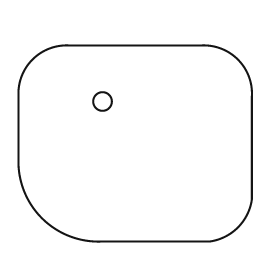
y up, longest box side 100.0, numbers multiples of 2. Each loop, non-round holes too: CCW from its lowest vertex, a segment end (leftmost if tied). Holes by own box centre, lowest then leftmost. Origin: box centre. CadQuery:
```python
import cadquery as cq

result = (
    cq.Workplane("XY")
    .moveTo(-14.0, -42.0)
    .lineTo(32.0, -42.0)
    .threePointArc((44.0, -36.0), (50.0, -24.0))
    .lineTo(50.0, 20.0)
    .threePointArc((44.0, 36.0), (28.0, 42.0))
    .lineTo(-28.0, 42.0)
    .threePointArc((-44.0, 36.0), (-50.0, 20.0))
    .lineTo(-50.0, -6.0)
    .threePointArc((-40.0, -32.0), (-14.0, -42.0))
    .close()
    .moveTo(-14.0, 18.0)
    .circle(4.0)
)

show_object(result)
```